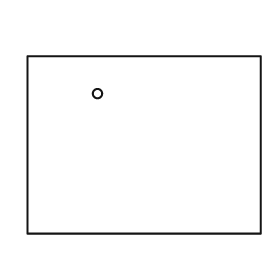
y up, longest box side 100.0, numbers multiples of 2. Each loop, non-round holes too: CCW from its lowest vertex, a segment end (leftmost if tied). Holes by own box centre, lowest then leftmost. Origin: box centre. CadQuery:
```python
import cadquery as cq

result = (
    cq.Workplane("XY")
    .moveTo(-50.0, -38.0)
    .lineTo(50.0, -38.0)
    .lineTo(50.0, 38.0)
    .lineTo(-50.0, 38.0)
    .close()
    .moveTo(-20.0, 22.0)
    .circle(2.0)
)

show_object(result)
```